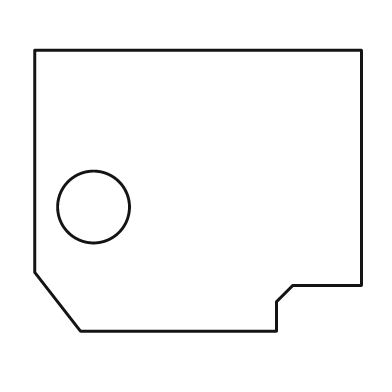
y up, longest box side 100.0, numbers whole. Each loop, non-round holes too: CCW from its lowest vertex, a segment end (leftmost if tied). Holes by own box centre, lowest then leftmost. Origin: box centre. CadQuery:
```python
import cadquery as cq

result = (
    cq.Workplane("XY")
    .moveTo(-36.0, -43.0)
    .lineTo(24.0, -43.0)
    .lineTo(24.0, -34.0)
    .lineTo(29.0, -29.0)
    .lineTo(50.0, -29.0)
    .lineTo(50.0, 43.0)
    .lineTo(-50.0, 43.0)
    .lineTo(-50.0, -25.0)
    .close()
    .moveTo(-32.0, -5.0)
    .circle(11.0)
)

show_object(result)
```